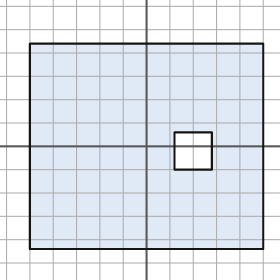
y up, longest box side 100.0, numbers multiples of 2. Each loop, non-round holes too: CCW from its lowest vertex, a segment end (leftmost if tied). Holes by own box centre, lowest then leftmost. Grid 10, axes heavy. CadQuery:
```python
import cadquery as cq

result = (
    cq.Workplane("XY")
    .moveTo(-50.0, -44.0)
    .lineTo(50.0, -44.0)
    .lineTo(50.0, 44.0)
    .lineTo(-50.0, 44.0)
    .close()
    .moveTo(12.0, -10.0)
    .lineTo(28.0, -10.0)
    .lineTo(28.0, 6.0)
    .lineTo(12.0, 6.0)
    .close()
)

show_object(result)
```